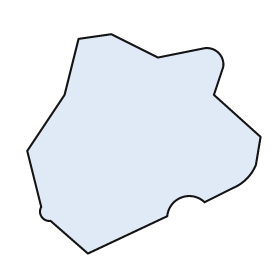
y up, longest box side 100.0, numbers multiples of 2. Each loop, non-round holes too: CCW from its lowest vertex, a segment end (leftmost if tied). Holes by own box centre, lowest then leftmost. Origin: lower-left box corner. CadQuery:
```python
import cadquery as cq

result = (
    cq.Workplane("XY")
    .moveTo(26.0, 0.0)
    .lineTo(60.0, 16.0)
    .threePointArc((66.0, 24.0), (76.0, 22.0))
    .lineTo(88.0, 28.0)
    .threePointArc((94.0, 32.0), (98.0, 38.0))
    .lineTo(100.0, 50.0)
    .lineTo(80.0, 68.0)
    .lineTo(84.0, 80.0)
    .threePointArc((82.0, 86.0), (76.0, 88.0))
    .lineTo(56.0, 84.0)
    .lineTo(36.0, 94.0)
    .lineTo(22.0, 92.0)
    .lineTo(16.0, 68.0)
    .lineTo(0.0, 44.0)
    .lineTo(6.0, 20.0)
    .threePointArc((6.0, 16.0), (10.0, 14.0))
    .close()
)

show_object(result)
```